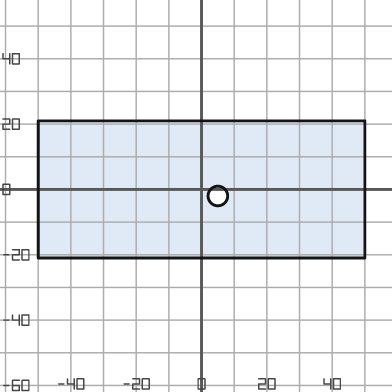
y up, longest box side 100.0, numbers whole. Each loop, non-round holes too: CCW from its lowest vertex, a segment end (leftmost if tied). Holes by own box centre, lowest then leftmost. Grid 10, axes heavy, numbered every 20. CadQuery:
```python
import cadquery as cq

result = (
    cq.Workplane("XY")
    .moveTo(-50.0, -21.0)
    .lineTo(50.0, -21.0)
    .lineTo(50.0, 21.0)
    .lineTo(-50.0, 21.0)
    .close()
    .moveTo(5.0, -2.0)
    .circle(3.0)
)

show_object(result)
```